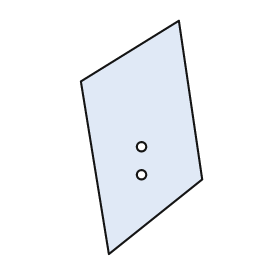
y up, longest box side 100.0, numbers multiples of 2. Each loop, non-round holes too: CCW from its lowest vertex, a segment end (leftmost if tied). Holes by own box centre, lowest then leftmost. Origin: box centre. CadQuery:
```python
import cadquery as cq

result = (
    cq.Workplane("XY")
    .moveTo(-14.0, -50.0)
    .lineTo(26.0, -18.0)
    .lineTo(16.0, 50.0)
    .lineTo(-26.0, 24.0)
    .close()
    .moveTo(0.0, -16.0)
    .circle(2.0)
    .moveTo(0.0, -4.0)
    .circle(2.0)
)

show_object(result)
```